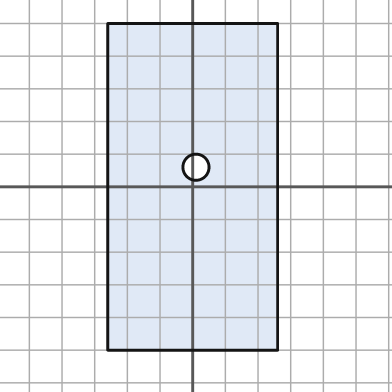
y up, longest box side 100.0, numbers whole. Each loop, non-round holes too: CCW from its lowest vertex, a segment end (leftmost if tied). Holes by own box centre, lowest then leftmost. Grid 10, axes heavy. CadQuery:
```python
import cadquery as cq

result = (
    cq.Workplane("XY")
    .moveTo(-26.0, -50.0)
    .lineTo(26.0, -50.0)
    .lineTo(26.0, 50.0)
    .lineTo(-26.0, 50.0)
    .close()
    .moveTo(1.0, 6.0)
    .circle(4.0)
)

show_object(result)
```